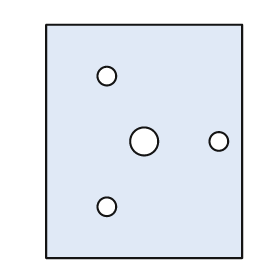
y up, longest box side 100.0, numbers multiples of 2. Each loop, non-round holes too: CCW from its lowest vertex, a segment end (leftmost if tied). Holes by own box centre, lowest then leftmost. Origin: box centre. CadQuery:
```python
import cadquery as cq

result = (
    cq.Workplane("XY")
    .moveTo(-42.0, -50.0)
    .lineTo(42.0, -50.0)
    .lineTo(42.0, 50.0)
    .lineTo(-42.0, 50.0)
    .close()
    .moveTo(-16.0, -28.0)
    .circle(4.0)
    .moveTo(0.0, 0.0)
    .circle(6.0)
    .moveTo(32.0, 0.0)
    .circle(4.0)
    .moveTo(-16.0, 28.0)
    .circle(4.0)
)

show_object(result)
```